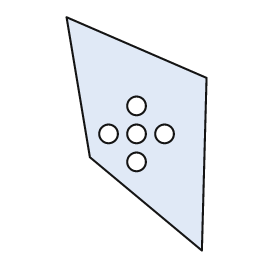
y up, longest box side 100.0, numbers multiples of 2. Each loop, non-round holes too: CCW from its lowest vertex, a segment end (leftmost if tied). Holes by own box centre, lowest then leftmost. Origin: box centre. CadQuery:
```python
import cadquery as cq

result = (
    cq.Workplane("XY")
    .moveTo(28.0, -50.0)
    .lineTo(30.0, 24.0)
    .lineTo(-30.0, 50.0)
    .lineTo(-20.0, -10.0)
    .close()
    .moveTo(0.0, -12.0)
    .circle(4.0)
    .moveTo(-12.0, 0.0)
    .circle(4.0)
    .moveTo(0.0, 0.0)
    .circle(4.0)
    .moveTo(12.0, 0.0)
    .circle(4.0)
    .moveTo(0.0, 12.0)
    .circle(4.0)
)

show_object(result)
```